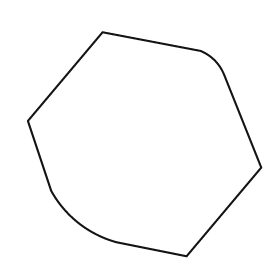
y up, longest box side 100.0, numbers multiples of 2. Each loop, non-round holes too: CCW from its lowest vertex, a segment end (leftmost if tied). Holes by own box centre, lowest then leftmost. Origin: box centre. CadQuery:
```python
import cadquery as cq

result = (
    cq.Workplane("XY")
    .moveTo(18.0, -48.0)
    .lineTo(50.0, -10.0)
    .lineTo(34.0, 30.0)
    .threePointArc((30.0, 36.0), (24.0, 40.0))
    .lineTo(-18.0, 48.0)
    .lineTo(-50.0, 10.0)
    .lineTo(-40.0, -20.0)
    .threePointArc((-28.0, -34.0), (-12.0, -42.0))
    .close()
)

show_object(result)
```